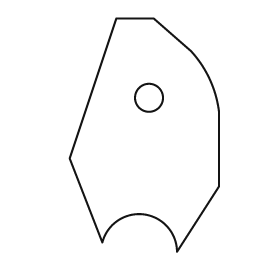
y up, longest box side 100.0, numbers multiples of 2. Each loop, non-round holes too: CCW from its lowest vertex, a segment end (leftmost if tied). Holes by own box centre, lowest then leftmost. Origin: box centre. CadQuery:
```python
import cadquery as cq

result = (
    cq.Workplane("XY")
    .moveTo(14.0, -50.0)
    .lineTo(32.0, -22.0)
    .lineTo(32.0, 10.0)
    .threePointArc((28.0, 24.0), (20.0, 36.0))
    .lineTo(4.0, 50.0)
    .lineTo(-12.0, 50.0)
    .lineTo(-32.0, -10.0)
    .lineTo(-18.0, -46.0)
    .threePointArc((0.0, -34.0), (14.0, -50.0))
    .close()
    .moveTo(2.0, 16.0)
    .circle(6.0)
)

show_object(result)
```